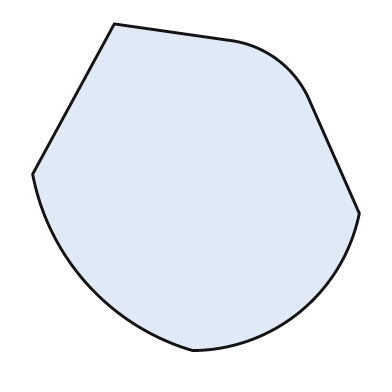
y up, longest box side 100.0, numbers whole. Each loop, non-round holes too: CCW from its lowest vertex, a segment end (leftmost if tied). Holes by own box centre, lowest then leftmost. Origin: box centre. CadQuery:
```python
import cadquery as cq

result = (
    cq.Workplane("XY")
    .moveTo(-1.0, -50.0)
    .threePointArc((32.0, -38.0), (50.0, -8.0))
    .lineTo(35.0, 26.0)
    .threePointArc((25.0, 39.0), (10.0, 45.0))
    .lineTo(-25.0, 50.0)
    .lineTo(-50.0, 4.0)
    .threePointArc((-33.0, -30.0), (-1.0, -50.0))
    .close()
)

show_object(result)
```